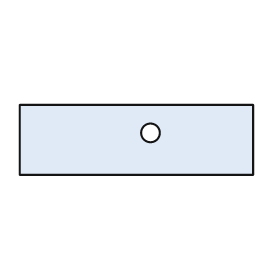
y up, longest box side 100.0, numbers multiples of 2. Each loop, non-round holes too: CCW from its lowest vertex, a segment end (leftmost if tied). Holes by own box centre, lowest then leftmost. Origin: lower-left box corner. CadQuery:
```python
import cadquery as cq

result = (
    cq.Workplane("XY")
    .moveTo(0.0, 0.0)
    .lineTo(100.0, 0.0)
    .lineTo(100.0, 30.0)
    .lineTo(0.0, 30.0)
    .close()
    .moveTo(56.0, 18.0)
    .circle(4.0)
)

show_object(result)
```